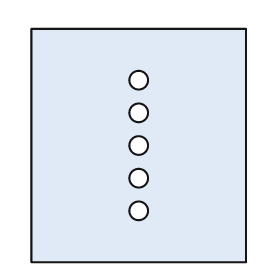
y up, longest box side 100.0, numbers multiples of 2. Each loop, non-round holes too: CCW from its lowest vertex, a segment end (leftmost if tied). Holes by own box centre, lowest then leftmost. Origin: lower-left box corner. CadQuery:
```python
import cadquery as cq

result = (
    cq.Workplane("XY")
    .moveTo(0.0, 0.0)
    .lineTo(92.0, 0.0)
    .lineTo(92.0, 100.0)
    .lineTo(0.0, 100.0)
    .close()
    .moveTo(46.0, 22.0)
    .circle(4.0)
    .moveTo(46.0, 36.0)
    .circle(4.0)
    .moveTo(46.0, 50.0)
    .circle(4.0)
    .moveTo(46.0, 64.0)
    .circle(4.0)
    .moveTo(46.0, 78.0)
    .circle(4.0)
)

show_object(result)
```